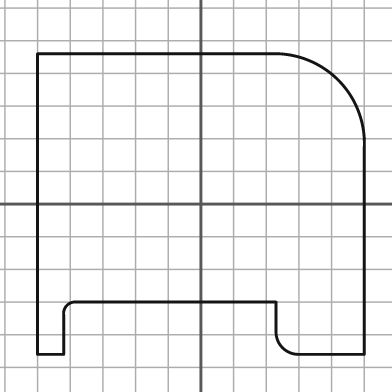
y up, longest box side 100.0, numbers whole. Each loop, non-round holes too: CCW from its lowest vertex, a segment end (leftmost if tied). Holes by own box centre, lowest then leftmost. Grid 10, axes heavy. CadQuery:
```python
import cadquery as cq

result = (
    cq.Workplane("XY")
    .moveTo(-50.0, -46.0)
    .lineTo(-42.0, -46.0)
    .lineTo(-42.0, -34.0)
    .threePointArc((-41.0, -31.0), (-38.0, -30.0))
    .lineTo(23.0, -30.0)
    .lineTo(23.0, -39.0)
    .threePointArc((25.0, -44.0), (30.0, -46.0))
    .lineTo(50.0, -46.0)
    .lineTo(50.0, 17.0)
    .threePointArc((42.0, 38.0), (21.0, 46.0))
    .lineTo(-50.0, 46.0)
    .close()
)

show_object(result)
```